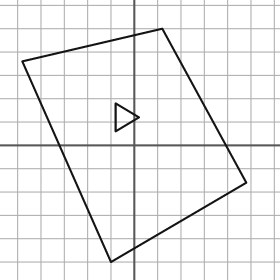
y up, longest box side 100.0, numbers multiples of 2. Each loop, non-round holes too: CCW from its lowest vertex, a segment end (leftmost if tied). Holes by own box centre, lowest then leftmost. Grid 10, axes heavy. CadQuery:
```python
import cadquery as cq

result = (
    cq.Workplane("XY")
    .moveTo(-10.0, -50.0)
    .lineTo(48.0, -16.0)
    .lineTo(12.0, 50.0)
    .lineTo(-48.0, 36.0)
    .close()
    .moveTo(-8.0, 6.0)
    .lineTo(2.0, 12.0)
    .lineTo(-8.0, 18.0)
    .close()
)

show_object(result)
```